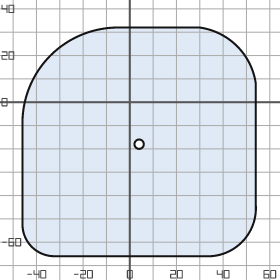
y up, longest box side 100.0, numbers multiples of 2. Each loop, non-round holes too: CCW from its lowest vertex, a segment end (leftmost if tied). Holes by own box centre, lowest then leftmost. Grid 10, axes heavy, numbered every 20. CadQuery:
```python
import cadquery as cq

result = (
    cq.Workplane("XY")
    .moveTo(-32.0, -66.0)
    .lineTo(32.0, -66.0)
    .threePointArc((48.0, -60.0), (54.0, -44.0))
    .lineTo(54.0, 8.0)
    .threePointArc((46.0, 24.0), (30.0, 32.0))
    .lineTo(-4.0, 32.0)
    .threePointArc((-34.0, 20.0), (-46.0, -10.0))
    .lineTo(-46.0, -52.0)
    .threePointArc((-42.0, -62.0), (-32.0, -66.0))
    .close()
    .moveTo(4.0, -18.0)
    .circle(2.0)
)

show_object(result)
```